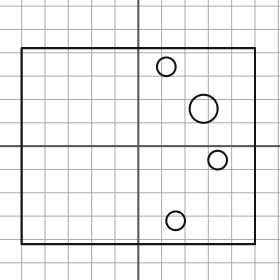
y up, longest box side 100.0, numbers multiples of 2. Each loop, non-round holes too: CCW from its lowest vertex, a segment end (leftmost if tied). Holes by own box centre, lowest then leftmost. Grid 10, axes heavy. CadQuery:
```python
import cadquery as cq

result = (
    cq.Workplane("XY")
    .moveTo(-50.0, -42.0)
    .lineTo(50.0, -42.0)
    .lineTo(50.0, 42.0)
    .lineTo(-50.0, 42.0)
    .close()
    .moveTo(16.0, -32.0)
    .circle(4.0)
    .moveTo(34.0, -6.0)
    .circle(4.0)
    .moveTo(28.0, 16.0)
    .circle(6.0)
    .moveTo(12.0, 34.0)
    .circle(4.0)
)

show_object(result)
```